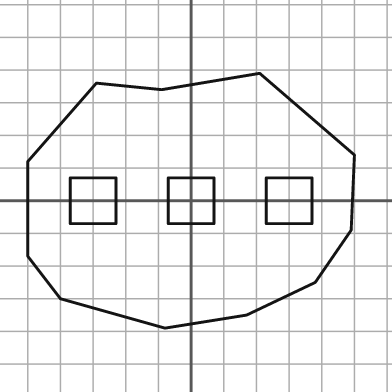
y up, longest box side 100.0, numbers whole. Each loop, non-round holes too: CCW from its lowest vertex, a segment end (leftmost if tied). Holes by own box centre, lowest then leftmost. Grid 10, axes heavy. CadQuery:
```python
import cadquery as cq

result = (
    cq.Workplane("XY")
    .moveTo(-8.0, -39.0)
    .lineTo(17.0, -35.0)
    .lineTo(38.0, -25.0)
    .lineTo(49.0, -9.0)
    .lineTo(50.0, 14.0)
    .lineTo(21.0, 39.0)
    .lineTo(-9.0, 34.0)
    .lineTo(-29.0, 36.0)
    .lineTo(-50.0, 12.0)
    .lineTo(-50.0, -17.0)
    .lineTo(-40.0, -30.0)
    .close()
    .moveTo(-37.0, -7.0)
    .lineTo(-23.0, -7.0)
    .lineTo(-23.0, 7.0)
    .lineTo(-37.0, 7.0)
    .close()
    .moveTo(-7.0, -7.0)
    .lineTo(7.0, -7.0)
    .lineTo(7.0, 7.0)
    .lineTo(-7.0, 7.0)
    .close()
    .moveTo(23.0, -7.0)
    .lineTo(37.0, -7.0)
    .lineTo(37.0, 7.0)
    .lineTo(23.0, 7.0)
    .close()
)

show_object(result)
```